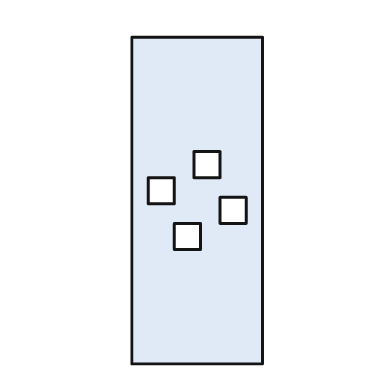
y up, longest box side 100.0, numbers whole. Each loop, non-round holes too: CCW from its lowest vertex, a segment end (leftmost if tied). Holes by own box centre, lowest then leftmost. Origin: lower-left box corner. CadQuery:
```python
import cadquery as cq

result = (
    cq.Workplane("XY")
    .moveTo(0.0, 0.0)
    .lineTo(40.0, 0.0)
    .lineTo(40.0, 100.0)
    .lineTo(0.0, 100.0)
    .close()
    .moveTo(13.0, 35.0)
    .lineTo(21.0, 35.0)
    .lineTo(21.0, 43.0)
    .lineTo(13.0, 43.0)
    .close()
    .moveTo(27.0, 43.0)
    .lineTo(35.0, 43.0)
    .lineTo(35.0, 51.0)
    .lineTo(27.0, 51.0)
    .close()
    .moveTo(5.0, 49.0)
    .lineTo(13.0, 49.0)
    .lineTo(13.0, 57.0)
    .lineTo(5.0, 57.0)
    .close()
    .moveTo(19.0, 57.0)
    .lineTo(27.0, 57.0)
    .lineTo(27.0, 65.0)
    .lineTo(19.0, 65.0)
    .close()
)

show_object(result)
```